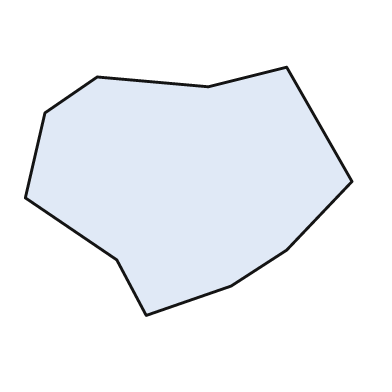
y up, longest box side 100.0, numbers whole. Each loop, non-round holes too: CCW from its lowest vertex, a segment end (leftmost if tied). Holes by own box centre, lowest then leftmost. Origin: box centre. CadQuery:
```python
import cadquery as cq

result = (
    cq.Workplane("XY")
    .moveTo(-13.0, -38.0)
    .lineTo(13.0, -29.0)
    .lineTo(30.0, -18.0)
    .lineTo(50.0, 3.0)
    .lineTo(30.0, 38.0)
    .lineTo(6.0, 32.0)
    .lineTo(-28.0, 35.0)
    .lineTo(-44.0, 24.0)
    .lineTo(-50.0, -2.0)
    .lineTo(-22.0, -21.0)
    .close()
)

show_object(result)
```